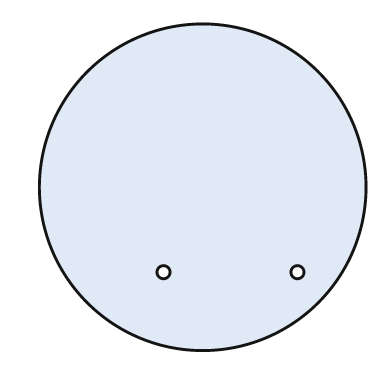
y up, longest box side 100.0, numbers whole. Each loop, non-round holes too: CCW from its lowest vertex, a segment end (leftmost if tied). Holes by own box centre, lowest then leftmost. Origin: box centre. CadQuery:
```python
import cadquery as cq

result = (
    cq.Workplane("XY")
    .moveTo(0.0, 0.0)
    .circle(50.0)
    .moveTo(-12.0, -26.0)
    .circle(2.0)
    .moveTo(29.0, -26.0)
    .circle(2.0)
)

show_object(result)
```